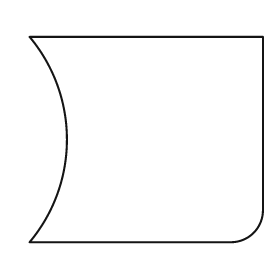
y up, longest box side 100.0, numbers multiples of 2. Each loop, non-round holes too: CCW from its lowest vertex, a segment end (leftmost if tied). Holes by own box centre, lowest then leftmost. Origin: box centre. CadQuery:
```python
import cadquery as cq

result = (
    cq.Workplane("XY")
    .moveTo(-50.0, -44.0)
    .lineTo(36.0, -44.0)
    .threePointArc((46.0, -40.0), (50.0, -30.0))
    .lineTo(50.0, 44.0)
    .lineTo(-50.0, 44.0)
    .threePointArc((-34.0, 0.0), (-50.0, -44.0))
    .close()
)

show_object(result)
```